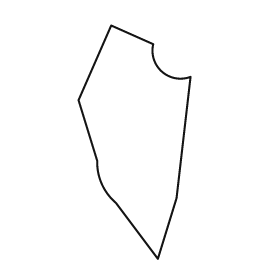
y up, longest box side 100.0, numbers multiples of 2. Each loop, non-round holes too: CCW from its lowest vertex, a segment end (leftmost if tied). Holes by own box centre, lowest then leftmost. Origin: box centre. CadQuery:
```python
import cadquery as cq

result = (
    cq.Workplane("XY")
    .moveTo(10.0, -50.0)
    .lineTo(18.0, -24.0)
    .lineTo(24.0, 28.0)
    .threePointArc((12.0, 30.0), (8.0, 42.0))
    .lineTo(-10.0, 50.0)
    .lineTo(-24.0, 18.0)
    .lineTo(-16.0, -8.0)
    .threePointArc((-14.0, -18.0), (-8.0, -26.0))
    .close()
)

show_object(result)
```